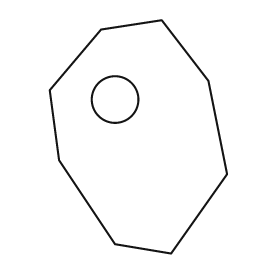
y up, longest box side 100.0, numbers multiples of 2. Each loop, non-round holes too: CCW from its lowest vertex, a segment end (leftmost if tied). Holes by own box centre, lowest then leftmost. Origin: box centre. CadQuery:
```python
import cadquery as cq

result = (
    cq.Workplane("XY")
    .moveTo(14.0, -50.0)
    .lineTo(38.0, -16.0)
    .lineTo(30.0, 24.0)
    .lineTo(10.0, 50.0)
    .lineTo(-16.0, 46.0)
    .lineTo(-38.0, 20.0)
    .lineTo(-34.0, -10.0)
    .lineTo(-10.0, -46.0)
    .close()
    .moveTo(-10.0, 16.0)
    .circle(10.0)
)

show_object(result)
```